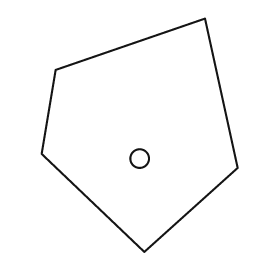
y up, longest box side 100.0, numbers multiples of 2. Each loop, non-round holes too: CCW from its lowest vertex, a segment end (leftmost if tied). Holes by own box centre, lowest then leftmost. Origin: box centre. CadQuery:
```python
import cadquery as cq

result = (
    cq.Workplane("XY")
    .moveTo(2.0, -50.0)
    .lineTo(42.0, -14.0)
    .lineTo(28.0, 50.0)
    .lineTo(-36.0, 28.0)
    .lineTo(-42.0, -8.0)
    .close()
    .moveTo(0.0, -10.0)
    .circle(4.0)
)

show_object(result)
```